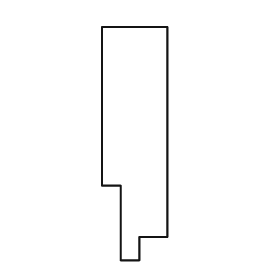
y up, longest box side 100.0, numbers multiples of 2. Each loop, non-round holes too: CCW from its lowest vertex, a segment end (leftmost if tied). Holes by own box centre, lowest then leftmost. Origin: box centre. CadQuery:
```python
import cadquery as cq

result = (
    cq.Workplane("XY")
    .moveTo(-6.0, -50.0)
    .lineTo(2.0, -50.0)
    .lineTo(2.0, -40.0)
    .lineTo(14.0, -40.0)
    .lineTo(14.0, 50.0)
    .lineTo(-14.0, 50.0)
    .lineTo(-14.0, -18.0)
    .lineTo(-6.0, -18.0)
    .close()
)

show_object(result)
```